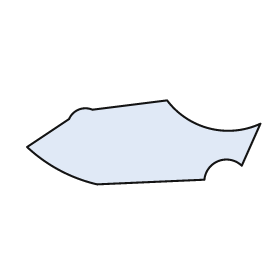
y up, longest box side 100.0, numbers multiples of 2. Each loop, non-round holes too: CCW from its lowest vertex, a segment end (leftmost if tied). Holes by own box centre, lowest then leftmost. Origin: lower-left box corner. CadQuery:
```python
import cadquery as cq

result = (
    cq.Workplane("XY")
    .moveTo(30.0, 0.0)
    .lineTo(76.0, 2.0)
    .threePointArc((82.0, 10.0), (92.0, 8.0))
    .lineTo(100.0, 26.0)
    .threePointArc((78.0, 24.0), (60.0, 36.0))
    .lineTo(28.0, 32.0)
    .threePointArc((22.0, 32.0), (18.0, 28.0))
    .lineTo(0.0, 16.0)
    .threePointArc((14.0, 6.0), (30.0, 0.0))
    .close()
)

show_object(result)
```